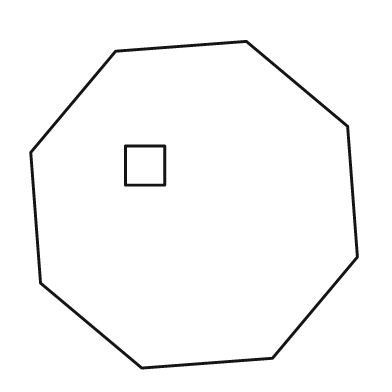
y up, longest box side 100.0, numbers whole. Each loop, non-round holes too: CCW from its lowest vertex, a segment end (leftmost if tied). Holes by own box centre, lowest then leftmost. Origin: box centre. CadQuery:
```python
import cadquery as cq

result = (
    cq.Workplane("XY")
    .moveTo(-16.0, -50.0)
    .lineTo(24.0, -47.0)
    .lineTo(50.0, -16.0)
    .lineTo(47.0, 24.0)
    .lineTo(16.0, 50.0)
    .lineTo(-24.0, 47.0)
    .lineTo(-50.0, 16.0)
    .lineTo(-47.0, -24.0)
    .close()
    .moveTo(-21.0, 6.0)
    .lineTo(-9.0, 6.0)
    .lineTo(-9.0, 18.0)
    .lineTo(-21.0, 18.0)
    .close()
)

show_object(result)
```